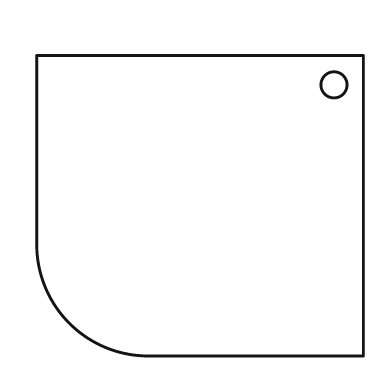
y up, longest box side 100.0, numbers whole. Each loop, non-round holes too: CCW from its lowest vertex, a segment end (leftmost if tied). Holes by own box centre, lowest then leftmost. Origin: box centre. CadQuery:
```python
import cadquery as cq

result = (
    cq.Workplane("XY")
    .moveTo(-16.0, -46.0)
    .lineTo(50.0, -46.0)
    .lineTo(50.0, 46.0)
    .lineTo(-50.0, 46.0)
    .lineTo(-50.0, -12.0)
    .threePointArc((-40.0, -36.0), (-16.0, -46.0))
    .close()
    .moveTo(41.0, 37.0)
    .circle(4.0)
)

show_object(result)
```